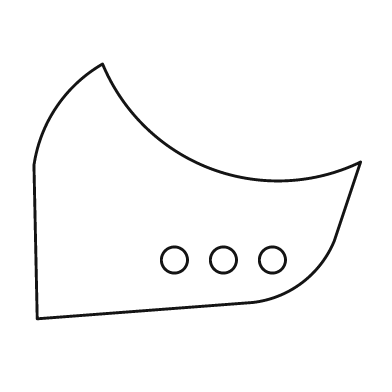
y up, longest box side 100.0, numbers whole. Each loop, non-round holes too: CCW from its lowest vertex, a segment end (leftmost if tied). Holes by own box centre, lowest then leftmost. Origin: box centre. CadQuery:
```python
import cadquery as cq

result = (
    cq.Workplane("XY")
    .moveTo(-49.0, -39.0)
    .lineTo(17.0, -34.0)
    .threePointArc((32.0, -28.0), (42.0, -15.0))
    .lineTo(50.0, 9.0)
    .threePointArc((4.0, 7.0), (-29.0, 39.0))
    .threePointArc((-43.0, 26.0), (-50.0, 8.0))
    .close()
    .moveTo(-7.0, -21.0)
    .circle(4.0)
    .moveTo(8.0, -21.0)
    .circle(4.0)
    .moveTo(23.0, -21.0)
    .circle(4.0)
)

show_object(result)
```